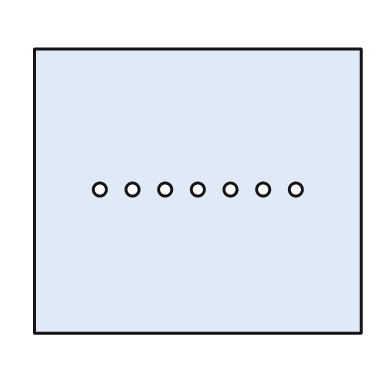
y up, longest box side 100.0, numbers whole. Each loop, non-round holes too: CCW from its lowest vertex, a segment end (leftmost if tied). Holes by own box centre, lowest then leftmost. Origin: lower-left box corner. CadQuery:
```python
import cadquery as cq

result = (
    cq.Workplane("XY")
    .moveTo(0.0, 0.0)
    .lineTo(100.0, 0.0)
    .lineTo(100.0, 87.0)
    .lineTo(0.0, 87.0)
    .close()
    .moveTo(20.0, 44.0)
    .circle(2.0)
    .moveTo(30.0, 44.0)
    .circle(2.0)
    .moveTo(40.0, 44.0)
    .circle(2.0)
    .moveTo(50.0, 44.0)
    .circle(2.0)
    .moveTo(60.0, 44.0)
    .circle(2.0)
    .moveTo(70.0, 44.0)
    .circle(2.0)
    .moveTo(80.0, 44.0)
    .circle(2.0)
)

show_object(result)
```